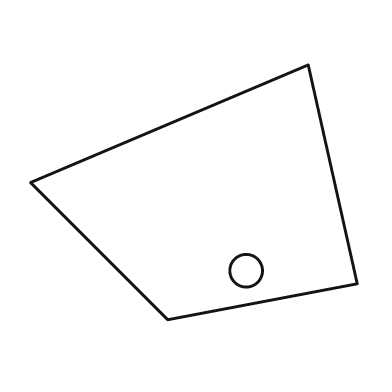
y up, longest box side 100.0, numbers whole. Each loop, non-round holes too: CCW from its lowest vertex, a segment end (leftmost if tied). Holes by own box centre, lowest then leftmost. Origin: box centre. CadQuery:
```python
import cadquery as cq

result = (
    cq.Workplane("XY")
    .moveTo(-8.0, -39.0)
    .lineTo(50.0, -28.0)
    .lineTo(35.0, 39.0)
    .lineTo(-50.0, 3.0)
    .close()
    .moveTo(16.0, -24.0)
    .circle(5.0)
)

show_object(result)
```